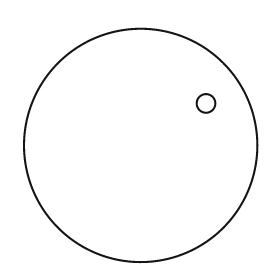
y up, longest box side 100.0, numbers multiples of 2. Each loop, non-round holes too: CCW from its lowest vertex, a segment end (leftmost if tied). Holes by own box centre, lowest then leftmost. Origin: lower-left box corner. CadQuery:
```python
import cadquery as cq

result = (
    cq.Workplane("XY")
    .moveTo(50.0, 50.0)
    .circle(50.0)
    .moveTo(78.0, 68.0)
    .circle(4.0)
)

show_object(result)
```